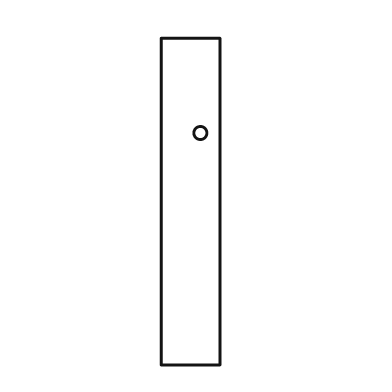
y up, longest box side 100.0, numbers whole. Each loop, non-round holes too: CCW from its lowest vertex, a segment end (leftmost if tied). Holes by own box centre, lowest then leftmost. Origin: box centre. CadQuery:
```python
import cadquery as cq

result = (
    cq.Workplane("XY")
    .moveTo(-9.0, -50.0)
    .lineTo(9.0, -50.0)
    .lineTo(9.0, 50.0)
    .lineTo(-9.0, 50.0)
    .close()
    .moveTo(3.0, 21.0)
    .circle(2.0)
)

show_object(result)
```